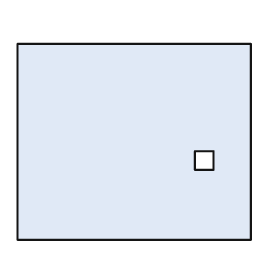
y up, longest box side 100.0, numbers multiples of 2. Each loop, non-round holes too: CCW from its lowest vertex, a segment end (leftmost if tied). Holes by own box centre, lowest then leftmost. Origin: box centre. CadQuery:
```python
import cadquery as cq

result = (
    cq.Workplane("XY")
    .moveTo(-50.0, -42.0)
    .lineTo(50.0, -42.0)
    .lineTo(50.0, 42.0)
    .lineTo(-50.0, 42.0)
    .close()
    .moveTo(26.0, -12.0)
    .lineTo(34.0, -12.0)
    .lineTo(34.0, -4.0)
    .lineTo(26.0, -4.0)
    .close()
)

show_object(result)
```